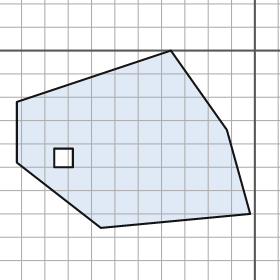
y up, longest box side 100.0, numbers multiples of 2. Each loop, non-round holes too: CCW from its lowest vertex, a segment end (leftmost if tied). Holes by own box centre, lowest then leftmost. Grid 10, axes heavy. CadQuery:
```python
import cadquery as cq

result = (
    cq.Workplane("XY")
    .moveTo(-66.0, -76.0)
    .lineTo(-2.0, -70.0)
    .lineTo(-12.0, -34.0)
    .lineTo(-36.0, 0.0)
    .lineTo(-102.0, -22.0)
    .lineTo(-102.0, -48.0)
    .close()
    .moveTo(-86.0, -50.0)
    .lineTo(-78.0, -50.0)
    .lineTo(-78.0, -42.0)
    .lineTo(-86.0, -42.0)
    .close()
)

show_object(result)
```